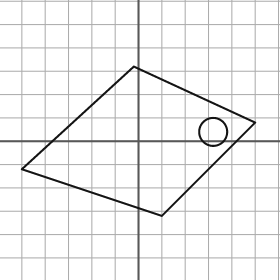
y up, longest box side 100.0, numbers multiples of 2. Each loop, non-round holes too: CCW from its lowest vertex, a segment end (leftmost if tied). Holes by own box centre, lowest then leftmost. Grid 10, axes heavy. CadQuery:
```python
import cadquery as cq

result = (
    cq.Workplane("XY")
    .moveTo(10.0, -32.0)
    .lineTo(50.0, 8.0)
    .lineTo(-2.0, 32.0)
    .lineTo(-50.0, -12.0)
    .close()
    .moveTo(32.0, 4.0)
    .circle(6.0)
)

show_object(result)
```